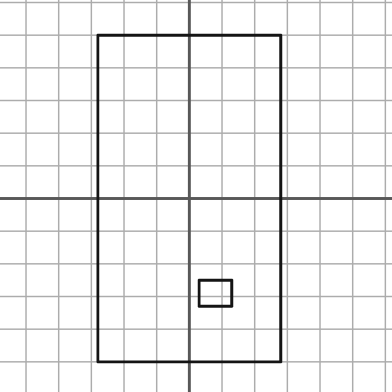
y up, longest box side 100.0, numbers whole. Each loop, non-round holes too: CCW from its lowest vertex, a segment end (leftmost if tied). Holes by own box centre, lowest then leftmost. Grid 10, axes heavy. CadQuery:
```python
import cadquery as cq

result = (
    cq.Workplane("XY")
    .moveTo(-28.0, -50.0)
    .lineTo(28.0, -50.0)
    .lineTo(28.0, 50.0)
    .lineTo(-28.0, 50.0)
    .close()
    .moveTo(3.0, -33.0)
    .lineTo(13.0, -33.0)
    .lineTo(13.0, -25.0)
    .lineTo(3.0, -25.0)
    .close()
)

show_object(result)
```